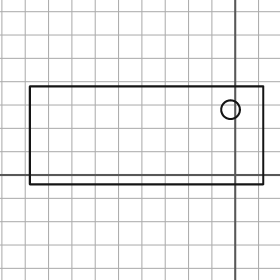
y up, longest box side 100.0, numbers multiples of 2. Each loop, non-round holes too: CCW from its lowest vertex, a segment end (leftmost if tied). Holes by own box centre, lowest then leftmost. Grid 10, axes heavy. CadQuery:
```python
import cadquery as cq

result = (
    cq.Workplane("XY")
    .moveTo(-88.0, -4.0)
    .lineTo(12.0, -4.0)
    .lineTo(12.0, 38.0)
    .lineTo(-88.0, 38.0)
    .close()
    .moveTo(-2.0, 28.0)
    .circle(4.0)
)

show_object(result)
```